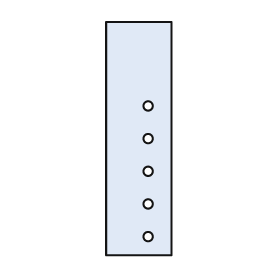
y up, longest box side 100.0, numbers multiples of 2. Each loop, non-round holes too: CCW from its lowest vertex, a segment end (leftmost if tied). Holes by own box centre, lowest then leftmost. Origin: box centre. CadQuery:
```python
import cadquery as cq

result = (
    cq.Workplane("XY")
    .moveTo(-14.0, -50.0)
    .lineTo(14.0, -50.0)
    .lineTo(14.0, 50.0)
    .lineTo(-14.0, 50.0)
    .close()
    .moveTo(4.0, -42.0)
    .circle(2.0)
    .moveTo(4.0, -28.0)
    .circle(2.0)
    .moveTo(4.0, -14.0)
    .circle(2.0)
    .moveTo(4.0, 0.0)
    .circle(2.0)
    .moveTo(4.0, 14.0)
    .circle(2.0)
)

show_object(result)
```